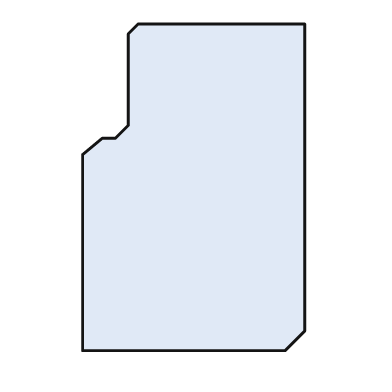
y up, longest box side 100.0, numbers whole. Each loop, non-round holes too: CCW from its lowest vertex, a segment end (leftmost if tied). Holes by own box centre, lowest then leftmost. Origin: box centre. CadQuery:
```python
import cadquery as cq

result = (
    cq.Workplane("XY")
    .moveTo(-34.0, -50.0)
    .lineTo(28.0, -50.0)
    .lineTo(34.0, -44.0)
    .lineTo(34.0, 50.0)
    .lineTo(-17.0, 50.0)
    .lineTo(-20.0, 47.0)
    .lineTo(-20.0, 19.0)
    .lineTo(-24.0, 15.0)
    .lineTo(-28.0, 15.0)
    .lineTo(-34.0, 10.0)
    .close()
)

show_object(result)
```